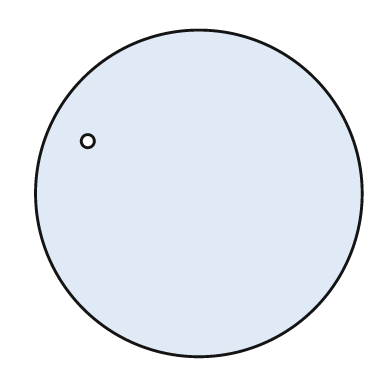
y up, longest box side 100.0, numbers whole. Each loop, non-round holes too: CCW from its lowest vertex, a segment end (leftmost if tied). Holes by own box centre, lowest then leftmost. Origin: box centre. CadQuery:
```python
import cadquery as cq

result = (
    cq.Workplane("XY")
    .moveTo(0.0, 0.0)
    .circle(50.0)
    .moveTo(-34.0, 16.0)
    .circle(2.0)
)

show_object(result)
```